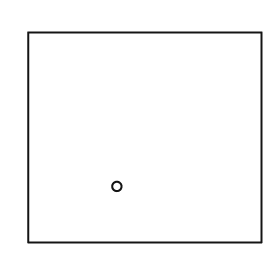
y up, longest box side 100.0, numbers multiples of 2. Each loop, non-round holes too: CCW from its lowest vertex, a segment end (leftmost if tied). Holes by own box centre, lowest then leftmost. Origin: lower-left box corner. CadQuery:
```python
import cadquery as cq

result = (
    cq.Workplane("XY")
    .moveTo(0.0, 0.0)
    .lineTo(100.0, 0.0)
    .lineTo(100.0, 90.0)
    .lineTo(0.0, 90.0)
    .close()
    .moveTo(38.0, 24.0)
    .circle(2.0)
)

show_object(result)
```